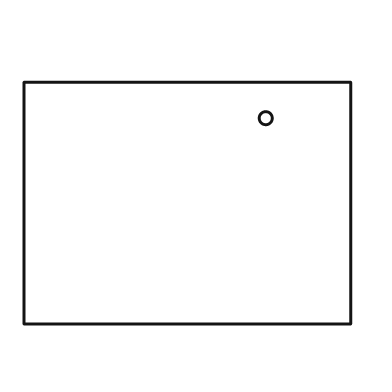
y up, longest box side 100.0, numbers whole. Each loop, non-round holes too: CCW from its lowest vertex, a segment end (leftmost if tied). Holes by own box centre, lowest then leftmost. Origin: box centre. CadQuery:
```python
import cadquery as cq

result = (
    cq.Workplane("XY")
    .moveTo(-50.0, -37.0)
    .lineTo(50.0, -37.0)
    .lineTo(50.0, 37.0)
    .lineTo(-50.0, 37.0)
    .close()
    .moveTo(24.0, 26.0)
    .circle(2.0)
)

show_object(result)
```